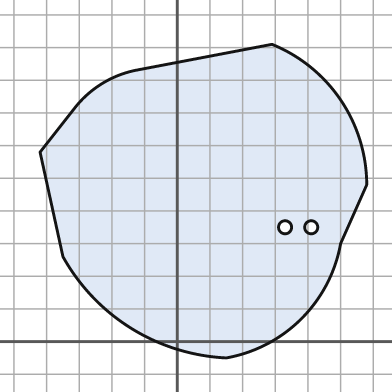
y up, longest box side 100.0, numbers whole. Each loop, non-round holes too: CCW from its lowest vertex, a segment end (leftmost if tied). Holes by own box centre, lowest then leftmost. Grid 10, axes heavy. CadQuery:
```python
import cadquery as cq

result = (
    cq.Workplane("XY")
    .moveTo(15.0, -5.0)
    .threePointArc((38.0, 7.0), (50.0, 30.0))
    .lineTo(58.0, 48.0)
    .threePointArc((50.0, 74.0), (29.0, 91.0))
    .lineTo(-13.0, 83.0)
    .threePointArc((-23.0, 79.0), (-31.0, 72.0))
    .lineTo(-42.0, 58.0)
    .lineTo(-35.0, 26.0)
    .threePointArc((-14.0, 4.0), (15.0, -5.0))
    .close()
    .moveTo(33.0, 35.0)
    .circle(2.0)
    .moveTo(41.0, 35.0)
    .circle(2.0)
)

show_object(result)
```